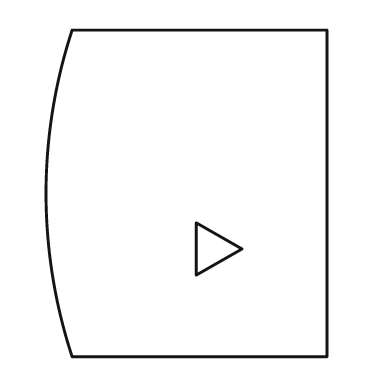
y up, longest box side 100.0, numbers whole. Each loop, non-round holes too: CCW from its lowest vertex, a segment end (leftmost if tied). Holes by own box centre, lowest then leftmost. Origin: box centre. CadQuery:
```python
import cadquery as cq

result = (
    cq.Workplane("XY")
    .moveTo(-35.0, -50.0)
    .lineTo(43.0, -50.0)
    .lineTo(43.0, 50.0)
    .lineTo(-35.0, 50.0)
    .threePointArc((-43.0, 0.0), (-35.0, -50.0))
    .close()
    .moveTo(3.0, -25.0)
    .lineTo(17.0, -17.0)
    .lineTo(3.0, -9.0)
    .close()
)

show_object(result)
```